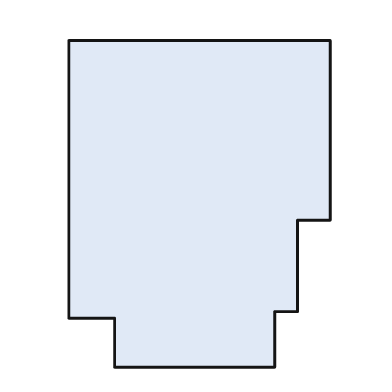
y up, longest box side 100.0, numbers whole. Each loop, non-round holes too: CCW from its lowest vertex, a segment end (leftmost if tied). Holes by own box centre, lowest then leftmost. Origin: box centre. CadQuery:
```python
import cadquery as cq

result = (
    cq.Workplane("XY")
    .moveTo(-26.0, -50.0)
    .lineTo(23.0, -50.0)
    .lineTo(23.0, -33.0)
    .lineTo(30.0, -33.0)
    .lineTo(30.0, -5.0)
    .lineTo(40.0, -5.0)
    .lineTo(40.0, 50.0)
    .lineTo(-40.0, 50.0)
    .lineTo(-40.0, -35.0)
    .lineTo(-26.0, -35.0)
    .close()
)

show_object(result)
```